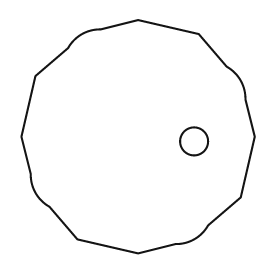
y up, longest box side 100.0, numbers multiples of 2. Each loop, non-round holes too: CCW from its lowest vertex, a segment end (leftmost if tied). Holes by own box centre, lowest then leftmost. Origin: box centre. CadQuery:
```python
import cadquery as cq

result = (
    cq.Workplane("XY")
    .moveTo(0.0, -50.0)
    .lineTo(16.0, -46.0)
    .threePointArc((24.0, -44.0), (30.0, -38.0))
    .lineTo(44.0, -26.0)
    .lineTo(50.0, 0.0)
    .lineTo(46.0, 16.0)
    .threePointArc((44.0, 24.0), (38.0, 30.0))
    .lineTo(26.0, 44.0)
    .lineTo(0.0, 50.0)
    .lineTo(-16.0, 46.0)
    .threePointArc((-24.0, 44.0), (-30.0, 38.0))
    .lineTo(-44.0, 26.0)
    .lineTo(-50.0, 0.0)
    .lineTo(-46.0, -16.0)
    .threePointArc((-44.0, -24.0), (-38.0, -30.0))
    .lineTo(-26.0, -44.0)
    .close()
    .moveTo(24.0, -2.0)
    .circle(6.0)
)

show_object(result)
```